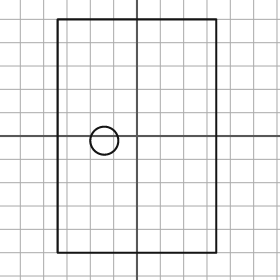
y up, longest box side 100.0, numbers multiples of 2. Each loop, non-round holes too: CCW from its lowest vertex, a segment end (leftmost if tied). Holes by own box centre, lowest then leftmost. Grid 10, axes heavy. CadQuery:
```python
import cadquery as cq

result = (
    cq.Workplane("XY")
    .moveTo(-34.0, -50.0)
    .lineTo(34.0, -50.0)
    .lineTo(34.0, 50.0)
    .lineTo(-34.0, 50.0)
    .close()
    .moveTo(-14.0, -2.0)
    .circle(6.0)
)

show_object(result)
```